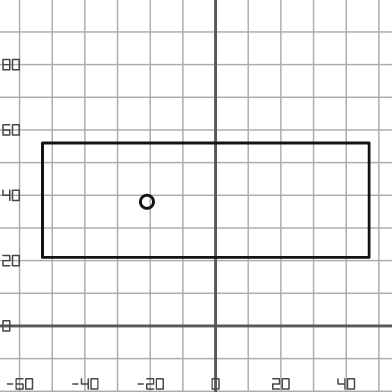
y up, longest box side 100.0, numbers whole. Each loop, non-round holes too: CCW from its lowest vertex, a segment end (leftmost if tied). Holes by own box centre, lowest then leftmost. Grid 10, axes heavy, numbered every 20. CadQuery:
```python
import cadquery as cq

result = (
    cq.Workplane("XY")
    .moveTo(-53.0, 21.0)
    .lineTo(47.0, 21.0)
    .lineTo(47.0, 56.0)
    .lineTo(-53.0, 56.0)
    .close()
    .moveTo(-21.0, 38.0)
    .circle(2.0)
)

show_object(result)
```